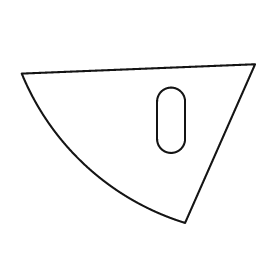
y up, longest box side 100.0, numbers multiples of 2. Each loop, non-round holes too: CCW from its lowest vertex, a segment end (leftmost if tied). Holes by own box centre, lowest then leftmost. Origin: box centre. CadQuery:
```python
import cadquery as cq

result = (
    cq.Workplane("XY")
    .moveTo(20.0, -34.0)
    .lineTo(50.0, 34.0)
    .lineTo(-50.0, 30.0)
    .threePointArc((-22.0, -10.0), (20.0, -34.0))
    .close()
    .moveTo(8.0, 2.0)
    .threePointArc((14.0, -4.0), (20.0, 2.0))
    .lineTo(20.0, 18.0)
    .threePointArc((14.0, 24.0), (8.0, 18.0))
    .close()
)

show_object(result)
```